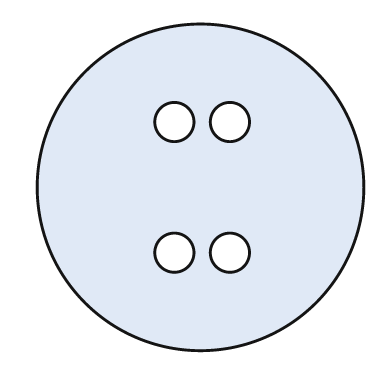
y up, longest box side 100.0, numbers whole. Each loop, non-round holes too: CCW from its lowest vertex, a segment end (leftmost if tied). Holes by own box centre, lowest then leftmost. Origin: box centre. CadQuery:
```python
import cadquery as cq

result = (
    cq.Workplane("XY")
    .moveTo(0.0, 0.0)
    .circle(50.0)
    .moveTo(-8.0, -20.0)
    .circle(6.0)
    .moveTo(9.0, -20.0)
    .circle(6.0)
    .moveTo(-8.0, 20.0)
    .circle(6.0)
    .moveTo(9.0, 20.0)
    .circle(6.0)
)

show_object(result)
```